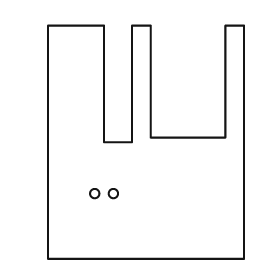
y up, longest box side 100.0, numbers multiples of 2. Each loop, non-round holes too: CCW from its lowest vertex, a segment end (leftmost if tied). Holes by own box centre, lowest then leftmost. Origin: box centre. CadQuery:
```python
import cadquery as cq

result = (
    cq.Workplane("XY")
    .moveTo(-42.0, -50.0)
    .lineTo(42.0, -50.0)
    .lineTo(42.0, 50.0)
    .lineTo(34.0, 50.0)
    .lineTo(34.0, 2.0)
    .lineTo(2.0, 2.0)
    .lineTo(2.0, 50.0)
    .lineTo(-6.0, 50.0)
    .lineTo(-6.0, 0.0)
    .lineTo(-18.0, 0.0)
    .lineTo(-18.0, 50.0)
    .lineTo(-42.0, 50.0)
    .close()
    .moveTo(-22.0, -22.0)
    .circle(2.0)
    .moveTo(-14.0, -22.0)
    .circle(2.0)
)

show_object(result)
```